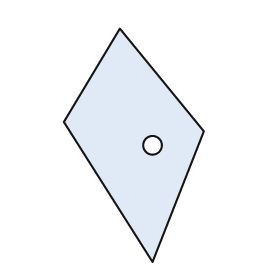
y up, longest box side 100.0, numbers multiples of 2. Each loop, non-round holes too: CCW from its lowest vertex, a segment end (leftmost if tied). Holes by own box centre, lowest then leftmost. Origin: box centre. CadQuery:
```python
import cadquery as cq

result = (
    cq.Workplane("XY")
    .moveTo(8.0, -50.0)
    .lineTo(30.0, 6.0)
    .lineTo(-6.0, 50.0)
    .lineTo(-30.0, 10.0)
    .close()
    .moveTo(8.0, 0.0)
    .circle(4.0)
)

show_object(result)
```